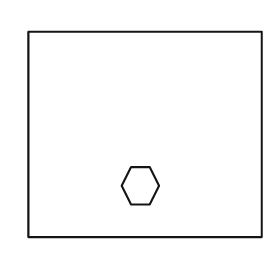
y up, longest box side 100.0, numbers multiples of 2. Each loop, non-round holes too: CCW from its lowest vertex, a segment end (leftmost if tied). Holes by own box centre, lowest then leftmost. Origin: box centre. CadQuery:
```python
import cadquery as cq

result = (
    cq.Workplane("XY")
    .moveTo(-50.0, -44.0)
    .lineTo(50.0, -44.0)
    .lineTo(50.0, 44.0)
    .lineTo(-50.0, 44.0)
    .close()
    .moveTo(-6.0, -30.0)
    .lineTo(2.0, -30.0)
    .lineTo(6.0, -22.0)
    .lineTo(2.0, -14.0)
    .lineTo(-6.0, -14.0)
    .lineTo(-10.0, -22.0)
    .close()
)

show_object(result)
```